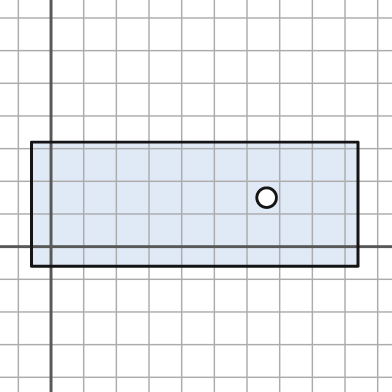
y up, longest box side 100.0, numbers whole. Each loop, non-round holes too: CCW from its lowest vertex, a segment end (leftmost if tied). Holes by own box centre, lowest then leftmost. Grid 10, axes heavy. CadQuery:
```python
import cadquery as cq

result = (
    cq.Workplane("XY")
    .moveTo(-6.0, -6.0)
    .lineTo(94.0, -6.0)
    .lineTo(94.0, 32.0)
    .lineTo(-6.0, 32.0)
    .close()
    .moveTo(66.0, 15.0)
    .circle(3.0)
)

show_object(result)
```